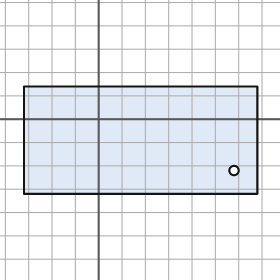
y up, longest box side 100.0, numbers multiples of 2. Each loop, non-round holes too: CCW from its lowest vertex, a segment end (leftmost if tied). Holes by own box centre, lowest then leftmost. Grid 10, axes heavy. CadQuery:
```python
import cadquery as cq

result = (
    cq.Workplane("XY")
    .moveTo(-32.0, -32.0)
    .lineTo(68.0, -32.0)
    .lineTo(68.0, 14.0)
    .lineTo(-32.0, 14.0)
    .close()
    .moveTo(58.0, -22.0)
    .circle(2.0)
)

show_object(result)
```